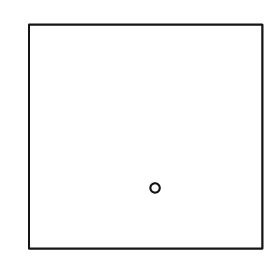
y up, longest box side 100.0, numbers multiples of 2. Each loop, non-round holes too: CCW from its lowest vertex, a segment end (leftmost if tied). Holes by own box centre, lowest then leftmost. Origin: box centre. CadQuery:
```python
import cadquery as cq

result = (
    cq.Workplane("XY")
    .moveTo(-50.0, -48.0)
    .lineTo(50.0, -48.0)
    .lineTo(50.0, 48.0)
    .lineTo(-50.0, 48.0)
    .close()
    .moveTo(4.0, -22.0)
    .circle(2.0)
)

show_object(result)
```